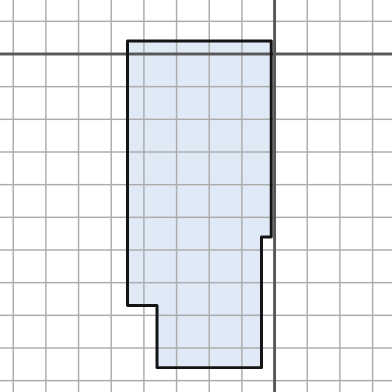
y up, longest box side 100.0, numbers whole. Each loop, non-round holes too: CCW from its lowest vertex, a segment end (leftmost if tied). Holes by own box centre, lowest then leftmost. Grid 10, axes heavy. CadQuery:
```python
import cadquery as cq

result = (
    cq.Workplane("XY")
    .moveTo(-36.0, -96.0)
    .lineTo(-4.0, -96.0)
    .lineTo(-4.0, -56.0)
    .lineTo(-1.0, -56.0)
    .lineTo(-1.0, 4.0)
    .lineTo(-45.0, 4.0)
    .lineTo(-45.0, -77.0)
    .lineTo(-36.0, -77.0)
    .close()
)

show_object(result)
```